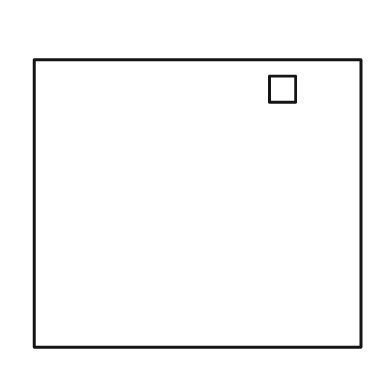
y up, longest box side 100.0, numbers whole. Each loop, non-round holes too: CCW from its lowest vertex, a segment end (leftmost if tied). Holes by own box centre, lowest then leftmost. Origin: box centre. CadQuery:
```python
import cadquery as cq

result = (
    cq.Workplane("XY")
    .moveTo(-50.0, -44.0)
    .lineTo(50.0, -44.0)
    .lineTo(50.0, 44.0)
    .lineTo(-50.0, 44.0)
    .close()
    .moveTo(22.0, 31.0)
    .lineTo(30.0, 31.0)
    .lineTo(30.0, 39.0)
    .lineTo(22.0, 39.0)
    .close()
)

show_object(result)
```